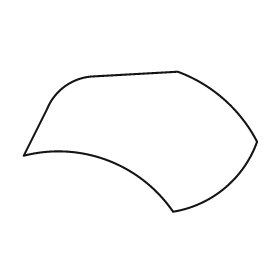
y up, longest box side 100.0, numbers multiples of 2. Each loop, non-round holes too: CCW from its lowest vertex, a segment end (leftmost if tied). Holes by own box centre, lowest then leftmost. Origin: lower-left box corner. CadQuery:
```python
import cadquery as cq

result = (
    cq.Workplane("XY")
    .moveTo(64.0, 0.0)
    .threePointArc((86.0, 10.0), (100.0, 30.0))
    .threePointArc((86.0, 48.0), (66.0, 60.0))
    .lineTo(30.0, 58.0)
    .threePointArc((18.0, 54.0), (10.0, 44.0))
    .lineTo(0.0, 24.0)
    .threePointArc((36.0, 22.0), (64.0, 0.0))
    .close()
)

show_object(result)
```